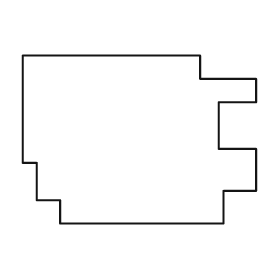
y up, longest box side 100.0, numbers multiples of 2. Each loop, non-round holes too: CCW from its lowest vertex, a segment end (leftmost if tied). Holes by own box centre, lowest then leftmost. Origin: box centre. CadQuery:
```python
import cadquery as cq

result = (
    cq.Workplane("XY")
    .moveTo(-34.0, -36.0)
    .lineTo(36.0, -36.0)
    .lineTo(36.0, -22.0)
    .lineTo(50.0, -22.0)
    .lineTo(50.0, -4.0)
    .lineTo(34.0, -4.0)
    .lineTo(34.0, 16.0)
    .lineTo(50.0, 16.0)
    .lineTo(50.0, 26.0)
    .lineTo(26.0, 26.0)
    .lineTo(26.0, 36.0)
    .lineTo(-50.0, 36.0)
    .lineTo(-50.0, -10.0)
    .lineTo(-44.0, -10.0)
    .lineTo(-44.0, -26.0)
    .lineTo(-34.0, -26.0)
    .close()
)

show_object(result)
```